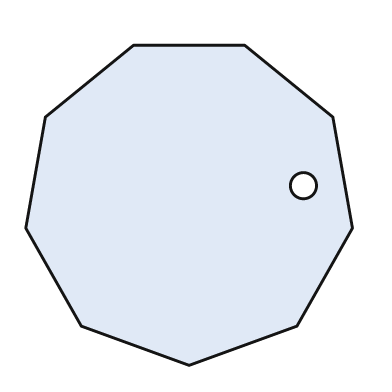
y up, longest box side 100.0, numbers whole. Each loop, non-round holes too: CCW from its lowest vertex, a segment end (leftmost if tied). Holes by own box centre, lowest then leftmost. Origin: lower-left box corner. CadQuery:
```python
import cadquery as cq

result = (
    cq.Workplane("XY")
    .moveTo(50.0, 0.0)
    .lineTo(83.0, 12.0)
    .lineTo(100.0, 42.0)
    .lineTo(94.0, 76.0)
    .lineTo(67.0, 98.0)
    .lineTo(33.0, 98.0)
    .lineTo(6.0, 76.0)
    .lineTo(0.0, 42.0)
    .lineTo(17.0, 12.0)
    .close()
    .moveTo(85.0, 55.0)
    .circle(4.0)
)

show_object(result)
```